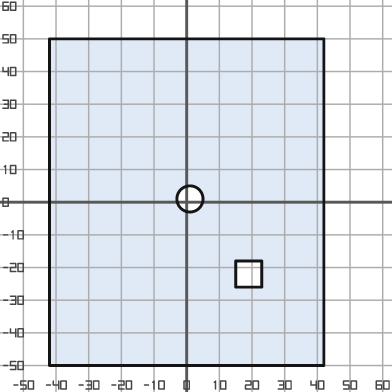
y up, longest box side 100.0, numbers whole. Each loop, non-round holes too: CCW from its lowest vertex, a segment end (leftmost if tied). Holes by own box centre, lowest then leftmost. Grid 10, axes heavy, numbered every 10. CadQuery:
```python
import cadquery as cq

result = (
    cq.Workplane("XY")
    .moveTo(-42.0, -50.0)
    .lineTo(42.0, -50.0)
    .lineTo(42.0, 50.0)
    .lineTo(-42.0, 50.0)
    .close()
    .moveTo(15.0, -26.0)
    .lineTo(23.0, -26.0)
    .lineTo(23.0, -18.0)
    .lineTo(15.0, -18.0)
    .close()
    .moveTo(1.0, 1.0)
    .circle(4.0)
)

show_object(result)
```